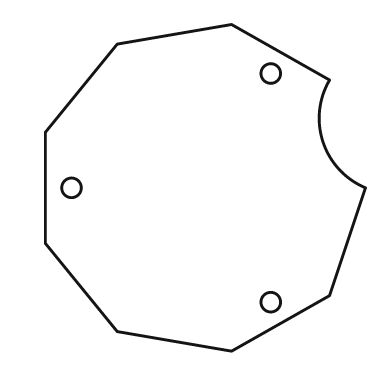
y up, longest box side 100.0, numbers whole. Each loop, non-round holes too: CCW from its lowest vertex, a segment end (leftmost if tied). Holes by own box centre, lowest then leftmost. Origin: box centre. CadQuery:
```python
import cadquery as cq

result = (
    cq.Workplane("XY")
    .moveTo(8.0, -50.0)
    .lineTo(38.0, -33.0)
    .lineTo(49.0, 0.0)
    .threePointArc((36.0, 14.0), (38.0, 33.0))
    .lineTo(8.0, 50.0)
    .lineTo(-27.0, 44.0)
    .lineTo(-49.0, 17.0)
    .lineTo(-49.0, -17.0)
    .lineTo(-27.0, -44.0)
    .close()
    .moveTo(20.0, -35.0)
    .circle(3.0)
    .moveTo(-41.0, 0.0)
    .circle(3.0)
    .moveTo(20.0, 35.0)
    .circle(3.0)
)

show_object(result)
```